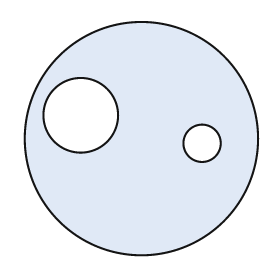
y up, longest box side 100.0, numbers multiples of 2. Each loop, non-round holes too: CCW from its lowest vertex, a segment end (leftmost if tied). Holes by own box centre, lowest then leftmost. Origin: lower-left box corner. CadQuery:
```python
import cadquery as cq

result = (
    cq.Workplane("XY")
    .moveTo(50.0, 50.0)
    .circle(50.0)
    .moveTo(76.0, 48.0)
    .circle(8.0)
    .moveTo(24.0, 60.0)
    .circle(16.0)
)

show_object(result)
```